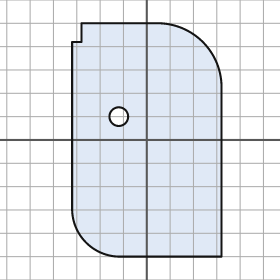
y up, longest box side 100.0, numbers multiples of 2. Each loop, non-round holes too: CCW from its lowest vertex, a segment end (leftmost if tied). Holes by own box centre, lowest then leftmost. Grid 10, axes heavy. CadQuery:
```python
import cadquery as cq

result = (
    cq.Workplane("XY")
    .moveTo(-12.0, -50.0)
    .lineTo(32.0, -50.0)
    .lineTo(32.0, 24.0)
    .threePointArc((24.0, 42.0), (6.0, 50.0))
    .lineTo(-28.0, 50.0)
    .lineTo(-28.0, 42.0)
    .lineTo(-32.0, 42.0)
    .lineTo(-32.0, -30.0)
    .threePointArc((-26.0, -44.0), (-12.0, -50.0))
    .close()
    .moveTo(-12.0, 10.0)
    .circle(4.0)
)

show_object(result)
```